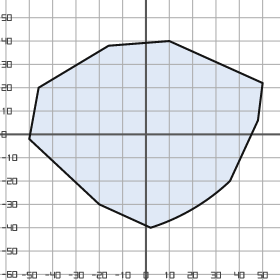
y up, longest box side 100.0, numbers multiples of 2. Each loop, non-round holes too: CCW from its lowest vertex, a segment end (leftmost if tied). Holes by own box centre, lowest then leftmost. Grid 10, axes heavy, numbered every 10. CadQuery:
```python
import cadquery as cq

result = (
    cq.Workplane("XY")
    .moveTo(2.0, -40.0)
    .threePointArc((20.0, -32.0), (36.0, -20.0))
    .lineTo(48.0, 6.0)
    .lineTo(50.0, 22.0)
    .lineTo(10.0, 40.0)
    .lineTo(-16.0, 38.0)
    .lineTo(-46.0, 20.0)
    .lineTo(-50.0, -2.0)
    .lineTo(-20.0, -30.0)
    .close()
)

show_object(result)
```